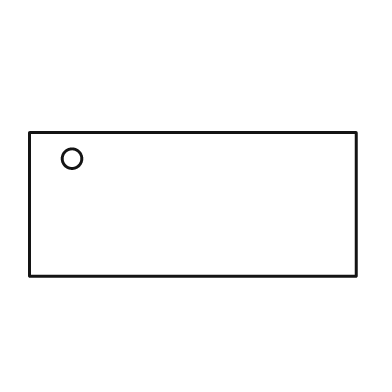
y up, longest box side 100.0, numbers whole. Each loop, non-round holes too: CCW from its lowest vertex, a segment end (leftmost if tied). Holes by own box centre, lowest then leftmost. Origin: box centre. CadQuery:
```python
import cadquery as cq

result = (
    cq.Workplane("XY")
    .moveTo(-50.0, -22.0)
    .lineTo(50.0, -22.0)
    .lineTo(50.0, 22.0)
    .lineTo(-50.0, 22.0)
    .close()
    .moveTo(-37.0, 14.0)
    .circle(3.0)
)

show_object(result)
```